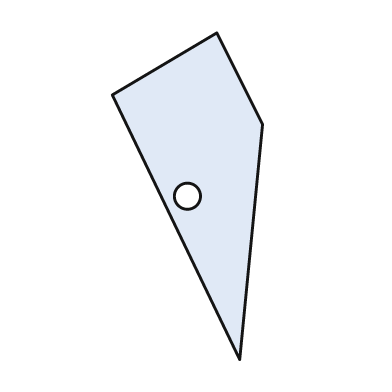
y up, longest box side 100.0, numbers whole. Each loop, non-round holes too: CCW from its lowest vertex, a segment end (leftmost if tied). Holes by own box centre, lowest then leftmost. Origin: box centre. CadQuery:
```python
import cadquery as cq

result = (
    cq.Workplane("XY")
    .moveTo(16.0, -50.0)
    .lineTo(23.0, 22.0)
    .lineTo(9.0, 50.0)
    .lineTo(-23.0, 31.0)
    .close()
    .moveTo(0.0, 0.0)
    .circle(4.0)
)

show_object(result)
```